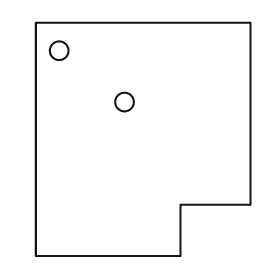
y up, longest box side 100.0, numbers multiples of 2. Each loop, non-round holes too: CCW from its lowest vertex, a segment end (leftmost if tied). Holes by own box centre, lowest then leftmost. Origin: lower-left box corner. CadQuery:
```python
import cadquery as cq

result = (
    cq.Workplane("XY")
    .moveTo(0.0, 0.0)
    .lineTo(62.0, 0.0)
    .lineTo(62.0, 22.0)
    .lineTo(92.0, 22.0)
    .lineTo(92.0, 100.0)
    .lineTo(0.0, 100.0)
    .close()
    .moveTo(38.0, 66.0)
    .circle(4.0)
    .moveTo(10.0, 88.0)
    .circle(4.0)
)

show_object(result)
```